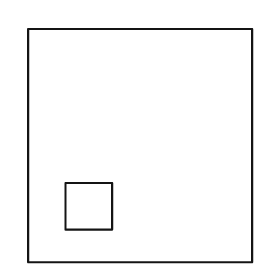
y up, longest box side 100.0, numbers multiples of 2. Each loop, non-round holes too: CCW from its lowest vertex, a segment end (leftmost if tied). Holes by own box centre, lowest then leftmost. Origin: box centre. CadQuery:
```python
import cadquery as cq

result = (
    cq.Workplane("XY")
    .moveTo(-48.0, -50.0)
    .lineTo(48.0, -50.0)
    .lineTo(48.0, 50.0)
    .lineTo(-48.0, 50.0)
    .close()
    .moveTo(-32.0, -36.0)
    .lineTo(-12.0, -36.0)
    .lineTo(-12.0, -16.0)
    .lineTo(-32.0, -16.0)
    .close()
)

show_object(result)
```